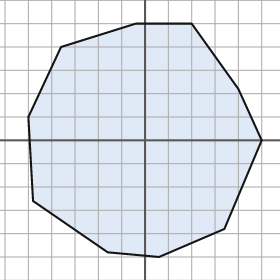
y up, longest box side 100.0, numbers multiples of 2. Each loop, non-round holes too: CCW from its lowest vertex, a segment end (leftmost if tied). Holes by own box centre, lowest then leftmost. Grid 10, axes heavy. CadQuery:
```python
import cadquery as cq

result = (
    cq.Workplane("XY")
    .moveTo(6.0, -50.0)
    .lineTo(34.0, -38.0)
    .lineTo(50.0, 0.0)
    .lineTo(40.0, 22.0)
    .lineTo(20.0, 50.0)
    .lineTo(-4.0, 50.0)
    .lineTo(-36.0, 40.0)
    .lineTo(-50.0, 10.0)
    .lineTo(-48.0, -26.0)
    .lineTo(-16.0, -48.0)
    .close()
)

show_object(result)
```